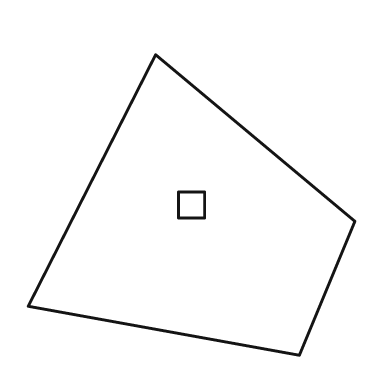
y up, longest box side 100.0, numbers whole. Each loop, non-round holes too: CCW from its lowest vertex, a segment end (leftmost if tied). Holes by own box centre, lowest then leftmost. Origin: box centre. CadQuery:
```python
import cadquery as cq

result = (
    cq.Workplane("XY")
    .moveTo(33.0, -46.0)
    .lineTo(50.0, -5.0)
    .lineTo(-11.0, 46.0)
    .lineTo(-50.0, -31.0)
    .close()
    .moveTo(-4.0, -4.0)
    .lineTo(4.0, -4.0)
    .lineTo(4.0, 4.0)
    .lineTo(-4.0, 4.0)
    .close()
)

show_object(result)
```